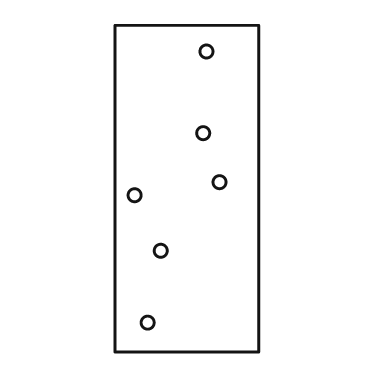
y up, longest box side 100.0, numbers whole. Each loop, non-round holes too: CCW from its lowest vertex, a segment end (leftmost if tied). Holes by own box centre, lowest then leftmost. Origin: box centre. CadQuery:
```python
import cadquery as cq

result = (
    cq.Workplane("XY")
    .moveTo(-22.0, -50.0)
    .lineTo(22.0, -50.0)
    .lineTo(22.0, 50.0)
    .lineTo(-22.0, 50.0)
    .close()
    .moveTo(-12.0, -41.0)
    .circle(2.0)
    .moveTo(-8.0, -19.0)
    .circle(2.0)
    .moveTo(-16.0, -2.0)
    .circle(2.0)
    .moveTo(10.0, 2.0)
    .circle(2.0)
    .moveTo(5.0, 17.0)
    .circle(2.0)
    .moveTo(6.0, 42.0)
    .circle(2.0)
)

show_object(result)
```